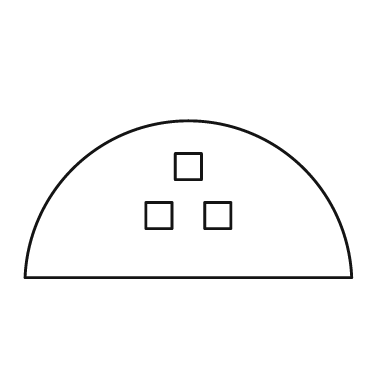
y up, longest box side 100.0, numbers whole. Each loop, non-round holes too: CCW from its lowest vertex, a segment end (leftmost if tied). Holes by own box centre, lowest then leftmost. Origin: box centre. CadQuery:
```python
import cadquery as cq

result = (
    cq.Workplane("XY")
    .moveTo(-50.0, -24.0)
    .lineTo(50.0, -24.0)
    .threePointArc((0.0, 24.0), (-50.0, -24.0))
    .close()
    .moveTo(-13.0, -9.0)
    .lineTo(-5.0, -9.0)
    .lineTo(-5.0, -1.0)
    .lineTo(-13.0, -1.0)
    .close()
    .moveTo(5.0, -9.0)
    .lineTo(13.0, -9.0)
    .lineTo(13.0, -1.0)
    .lineTo(5.0, -1.0)
    .close()
    .moveTo(-4.0, 6.0)
    .lineTo(4.0, 6.0)
    .lineTo(4.0, 14.0)
    .lineTo(-4.0, 14.0)
    .close()
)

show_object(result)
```